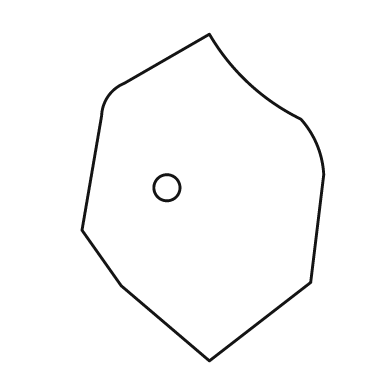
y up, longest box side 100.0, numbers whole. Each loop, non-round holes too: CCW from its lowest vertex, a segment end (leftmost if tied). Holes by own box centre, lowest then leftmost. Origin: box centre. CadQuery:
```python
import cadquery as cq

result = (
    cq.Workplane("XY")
    .moveTo(2.0, -50.0)
    .lineTo(33.0, -26.0)
    .lineTo(37.0, 7.0)
    .threePointArc((35.0, 16.0), (30.0, 24.0))
    .threePointArc((14.0, 35.0), (2.0, 50.0))
    .lineTo(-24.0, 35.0)
    .threePointArc((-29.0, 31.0), (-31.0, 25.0))
    .lineTo(-37.0, -10.0)
    .lineTo(-25.0, -27.0)
    .close()
    .moveTo(-11.0, 3.0)
    .circle(4.0)
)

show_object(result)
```